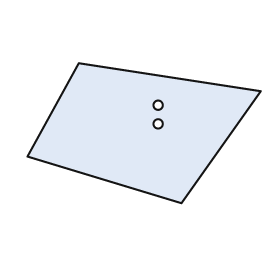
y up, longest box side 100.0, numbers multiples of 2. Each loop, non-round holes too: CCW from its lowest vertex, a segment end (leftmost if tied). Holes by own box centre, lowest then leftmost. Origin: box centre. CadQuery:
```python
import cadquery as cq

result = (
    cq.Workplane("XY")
    .moveTo(16.0, -30.0)
    .lineTo(50.0, 18.0)
    .lineTo(-28.0, 30.0)
    .lineTo(-50.0, -10.0)
    .close()
    .moveTo(6.0, 4.0)
    .circle(2.0)
    .moveTo(6.0, 12.0)
    .circle(2.0)
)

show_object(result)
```